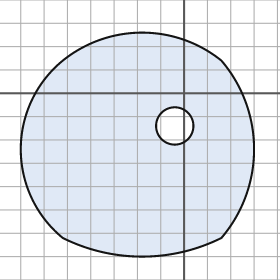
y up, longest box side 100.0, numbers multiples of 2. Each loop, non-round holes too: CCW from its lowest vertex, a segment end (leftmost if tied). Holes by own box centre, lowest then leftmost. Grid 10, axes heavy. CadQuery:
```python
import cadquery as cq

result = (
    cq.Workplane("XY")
    .moveTo(-52.0, -62.0)
    .threePointArc((-18.0, -70.0), (16.0, -62.0))
    .threePointArc((30.0, -24.0), (16.0, 14.0))
    .threePointArc((-18.0, 26.0), (-52.0, 14.0))
    .threePointArc((-70.0, -24.0), (-52.0, -62.0))
    .close()
    .moveTo(-4.0, -14.0)
    .circle(8.0)
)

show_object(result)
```